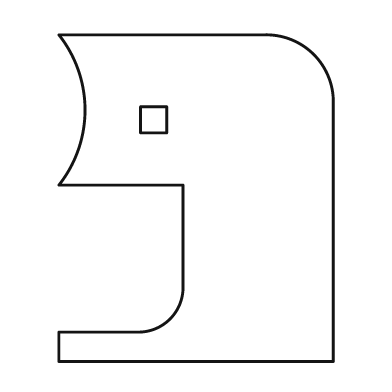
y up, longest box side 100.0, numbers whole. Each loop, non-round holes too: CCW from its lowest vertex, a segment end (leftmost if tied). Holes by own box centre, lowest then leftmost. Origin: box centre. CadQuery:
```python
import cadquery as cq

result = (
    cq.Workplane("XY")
    .moveTo(-42.0, -50.0)
    .lineTo(42.0, -50.0)
    .lineTo(42.0, 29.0)
    .threePointArc((36.0, 44.0), (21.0, 50.0))
    .lineTo(-42.0, 50.0)
    .threePointArc((-34.0, 27.0), (-42.0, 4.0))
    .lineTo(-4.0, 4.0)
    .lineTo(-4.0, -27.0)
    .threePointArc((-8.0, -37.0), (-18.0, -41.0))
    .lineTo(-42.0, -41.0)
    .close()
    .moveTo(-17.0, 20.0)
    .lineTo(-9.0, 20.0)
    .lineTo(-9.0, 28.0)
    .lineTo(-17.0, 28.0)
    .close()
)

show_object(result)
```